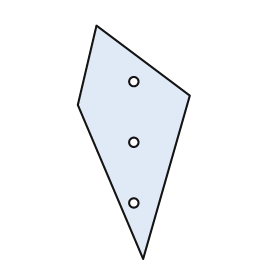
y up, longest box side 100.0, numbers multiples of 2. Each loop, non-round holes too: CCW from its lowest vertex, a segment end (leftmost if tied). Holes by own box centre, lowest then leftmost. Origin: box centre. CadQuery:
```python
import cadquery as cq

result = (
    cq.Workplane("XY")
    .moveTo(4.0, -50.0)
    .lineTo(24.0, 20.0)
    .lineTo(-16.0, 50.0)
    .lineTo(-24.0, 16.0)
    .close()
    .moveTo(0.0, -26.0)
    .circle(2.0)
    .moveTo(0.0, 0.0)
    .circle(2.0)
    .moveTo(0.0, 26.0)
    .circle(2.0)
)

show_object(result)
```